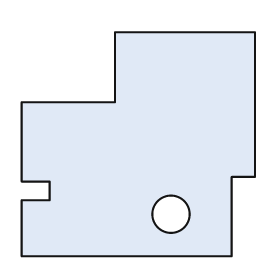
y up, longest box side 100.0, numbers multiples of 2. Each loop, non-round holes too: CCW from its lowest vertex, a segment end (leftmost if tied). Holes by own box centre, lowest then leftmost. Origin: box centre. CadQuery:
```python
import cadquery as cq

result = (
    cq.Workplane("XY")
    .moveTo(-50.0, -48.0)
    .lineTo(40.0, -48.0)
    .lineTo(40.0, -14.0)
    .lineTo(50.0, -14.0)
    .lineTo(50.0, 48.0)
    .lineTo(-10.0, 48.0)
    .lineTo(-10.0, 18.0)
    .lineTo(-50.0, 18.0)
    .lineTo(-50.0, -16.0)
    .lineTo(-38.0, -16.0)
    .lineTo(-38.0, -24.0)
    .lineTo(-50.0, -24.0)
    .close()
    .moveTo(14.0, -30.0)
    .circle(8.0)
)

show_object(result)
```